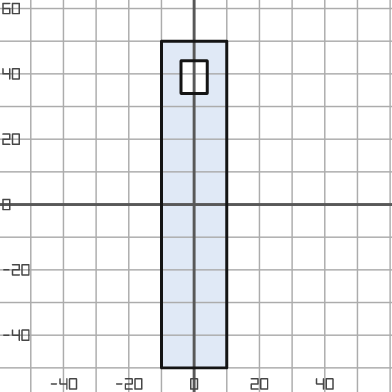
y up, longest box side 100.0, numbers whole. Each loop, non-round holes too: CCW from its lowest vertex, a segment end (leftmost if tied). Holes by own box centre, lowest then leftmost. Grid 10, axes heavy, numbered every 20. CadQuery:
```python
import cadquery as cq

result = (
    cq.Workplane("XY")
    .moveTo(-10.0, -50.0)
    .lineTo(10.0, -50.0)
    .lineTo(10.0, 50.0)
    .lineTo(-10.0, 50.0)
    .close()
    .moveTo(-4.0, 34.0)
    .lineTo(4.0, 34.0)
    .lineTo(4.0, 44.0)
    .lineTo(-4.0, 44.0)
    .close()
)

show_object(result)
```